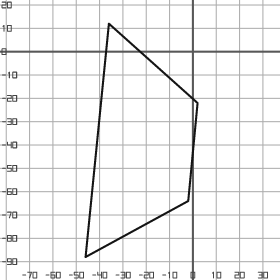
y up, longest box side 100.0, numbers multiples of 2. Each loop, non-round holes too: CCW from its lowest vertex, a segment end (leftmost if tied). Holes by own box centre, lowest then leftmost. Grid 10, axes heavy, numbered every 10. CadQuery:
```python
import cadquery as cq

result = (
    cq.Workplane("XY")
    .moveTo(-46.0, -88.0)
    .lineTo(-2.0, -64.0)
    .lineTo(2.0, -22.0)
    .lineTo(-36.0, 12.0)
    .close()
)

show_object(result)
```